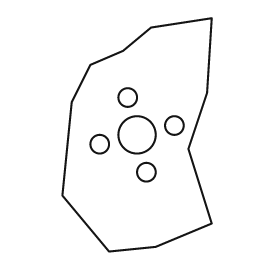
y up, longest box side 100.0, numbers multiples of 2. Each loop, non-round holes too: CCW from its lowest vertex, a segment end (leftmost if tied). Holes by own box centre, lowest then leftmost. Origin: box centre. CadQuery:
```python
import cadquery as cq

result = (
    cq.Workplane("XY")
    .moveTo(-12.0, -50.0)
    .lineTo(8.0, -48.0)
    .lineTo(32.0, -38.0)
    .lineTo(22.0, -6.0)
    .lineTo(30.0, 18.0)
    .lineTo(32.0, 50.0)
    .lineTo(6.0, 46.0)
    .lineTo(-6.0, 36.0)
    .lineTo(-20.0, 30.0)
    .lineTo(-28.0, 14.0)
    .lineTo(-32.0, -26.0)
    .close()
    .moveTo(4.0, -16.0)
    .circle(4.0)
    .moveTo(-16.0, -4.0)
    .circle(4.0)
    .moveTo(0.0, 0.0)
    .circle(8.0)
    .moveTo(16.0, 4.0)
    .circle(4.0)
    .moveTo(-4.0, 16.0)
    .circle(4.0)
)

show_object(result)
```